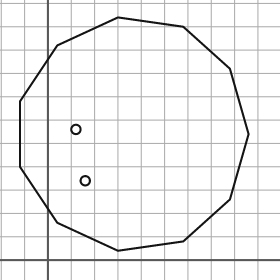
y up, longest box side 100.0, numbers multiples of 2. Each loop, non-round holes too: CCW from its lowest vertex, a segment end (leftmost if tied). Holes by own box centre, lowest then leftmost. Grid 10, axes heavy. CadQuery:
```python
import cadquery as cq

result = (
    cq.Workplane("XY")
    .moveTo(30.0, 4.0)
    .lineTo(58.0, 8.0)
    .lineTo(78.0, 26.0)
    .lineTo(86.0, 54.0)
    .lineTo(78.0, 82.0)
    .lineTo(58.0, 100.0)
    .lineTo(30.0, 104.0)
    .lineTo(4.0, 92.0)
    .lineTo(-12.0, 68.0)
    .lineTo(-12.0, 40.0)
    .lineTo(4.0, 16.0)
    .close()
    .moveTo(16.0, 34.0)
    .circle(2.0)
    .moveTo(12.0, 56.0)
    .circle(2.0)
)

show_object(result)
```